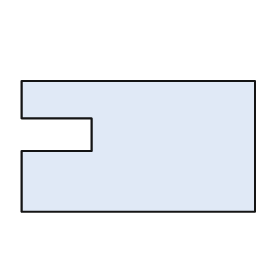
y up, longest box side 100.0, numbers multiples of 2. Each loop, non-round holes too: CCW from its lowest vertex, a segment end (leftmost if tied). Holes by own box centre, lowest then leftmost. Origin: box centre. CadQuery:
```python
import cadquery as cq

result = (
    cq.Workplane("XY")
    .moveTo(-50.0, -28.0)
    .lineTo(50.0, -28.0)
    .lineTo(50.0, 28.0)
    .lineTo(-50.0, 28.0)
    .lineTo(-50.0, 12.0)
    .lineTo(-20.0, 12.0)
    .lineTo(-20.0, -2.0)
    .lineTo(-50.0, -2.0)
    .close()
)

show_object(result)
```